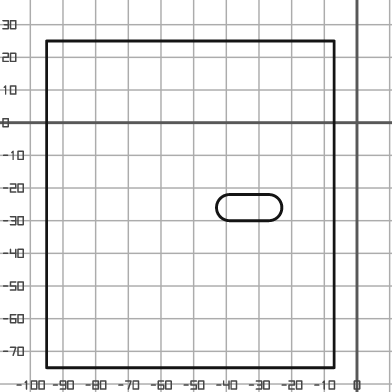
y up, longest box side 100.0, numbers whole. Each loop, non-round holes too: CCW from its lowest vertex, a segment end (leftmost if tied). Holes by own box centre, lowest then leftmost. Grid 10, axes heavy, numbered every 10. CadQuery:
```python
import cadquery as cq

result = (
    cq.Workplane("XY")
    .moveTo(-95.0, -75.0)
    .lineTo(-7.0, -75.0)
    .lineTo(-7.0, 25.0)
    .lineTo(-95.0, 25.0)
    .close()
    .moveTo(-39.0, -30.0)
    .lineTo(-27.0, -30.0)
    .threePointArc((-23.0, -26.0), (-27.0, -22.0))
    .lineTo(-39.0, -22.0)
    .threePointArc((-43.0, -26.0), (-39.0, -30.0))
    .close()
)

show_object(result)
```